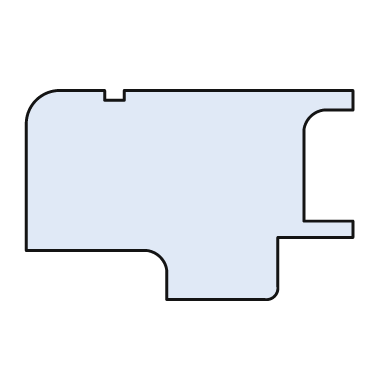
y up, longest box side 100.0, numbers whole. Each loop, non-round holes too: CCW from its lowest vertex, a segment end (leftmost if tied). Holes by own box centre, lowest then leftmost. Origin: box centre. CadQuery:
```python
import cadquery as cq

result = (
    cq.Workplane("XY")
    .moveTo(-7.0, -32.0)
    .lineTo(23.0, -32.0)
    .threePointArc((26.0, -31.0), (27.0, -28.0))
    .lineTo(27.0, -13.0)
    .lineTo(50.0, -13.0)
    .lineTo(50.0, -8.0)
    .lineTo(35.0, -8.0)
    .lineTo(35.0, 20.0)
    .threePointArc((37.0, 24.0), (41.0, 26.0))
    .lineTo(50.0, 26.0)
    .lineTo(50.0, 32.0)
    .lineTo(-20.0, 32.0)
    .lineTo(-20.0, 29.0)
    .lineTo(-26.0, 29.0)
    .lineTo(-26.0, 32.0)
    .lineTo(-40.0, 32.0)
    .threePointArc((-47.0, 29.0), (-50.0, 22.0))
    .lineTo(-50.0, -17.0)
    .lineTo(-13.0, -17.0)
    .threePointArc((-9.0, -19.0), (-7.0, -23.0))
    .close()
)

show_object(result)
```